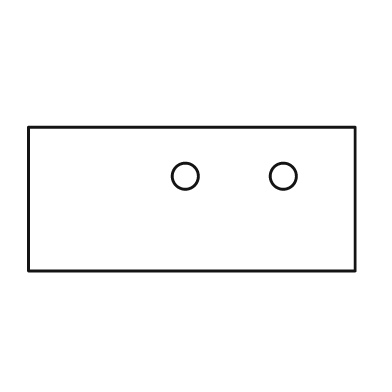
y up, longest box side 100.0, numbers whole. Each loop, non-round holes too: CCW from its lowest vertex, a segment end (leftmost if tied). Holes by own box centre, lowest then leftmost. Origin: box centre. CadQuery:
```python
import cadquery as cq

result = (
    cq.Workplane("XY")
    .moveTo(-50.0, -22.0)
    .lineTo(50.0, -22.0)
    .lineTo(50.0, 22.0)
    .lineTo(-50.0, 22.0)
    .close()
    .moveTo(-2.0, 7.0)
    .circle(4.0)
    .moveTo(28.0, 7.0)
    .circle(4.0)
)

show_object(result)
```